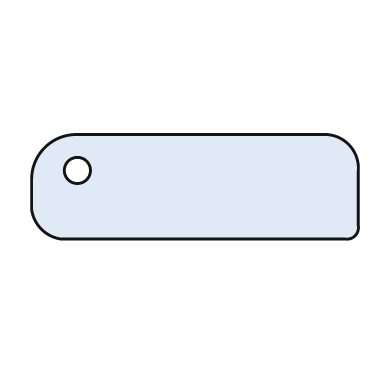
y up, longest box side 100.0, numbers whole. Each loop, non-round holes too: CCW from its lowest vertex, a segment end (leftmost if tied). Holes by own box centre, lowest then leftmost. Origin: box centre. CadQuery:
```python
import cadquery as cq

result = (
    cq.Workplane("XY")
    .moveTo(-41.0, -16.0)
    .lineTo(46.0, -16.0)
    .threePointArc((49.0, -15.0), (50.0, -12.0))
    .lineTo(50.0, 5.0)
    .threePointArc((47.0, 13.0), (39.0, 16.0))
    .lineTo(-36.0, 16.0)
    .threePointArc((-46.0, 12.0), (-50.0, 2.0))
    .lineTo(-50.0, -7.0)
    .threePointArc((-47.0, -13.0), (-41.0, -16.0))
    .close()
    .moveTo(-36.0, 5.0)
    .circle(4.0)
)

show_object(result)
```